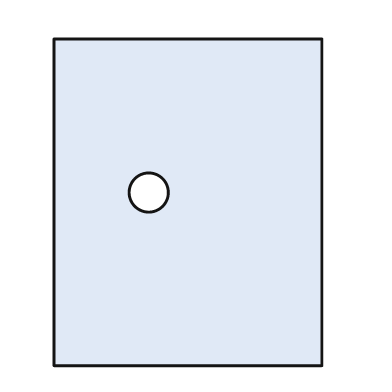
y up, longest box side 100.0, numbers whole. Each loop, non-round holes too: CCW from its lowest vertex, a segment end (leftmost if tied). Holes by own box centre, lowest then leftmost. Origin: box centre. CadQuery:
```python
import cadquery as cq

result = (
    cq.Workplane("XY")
    .moveTo(-41.0, -50.0)
    .lineTo(41.0, -50.0)
    .lineTo(41.0, 50.0)
    .lineTo(-41.0, 50.0)
    .close()
    .moveTo(-12.0, 3.0)
    .circle(6.0)
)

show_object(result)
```